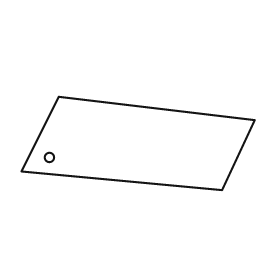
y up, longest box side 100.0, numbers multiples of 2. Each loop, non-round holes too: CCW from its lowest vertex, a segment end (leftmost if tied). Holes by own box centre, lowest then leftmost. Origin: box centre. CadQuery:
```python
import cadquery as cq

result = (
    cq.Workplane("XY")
    .moveTo(36.0, -20.0)
    .lineTo(50.0, 10.0)
    .lineTo(-34.0, 20.0)
    .lineTo(-50.0, -12.0)
    .close()
    .moveTo(-38.0, -6.0)
    .circle(2.0)
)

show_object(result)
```